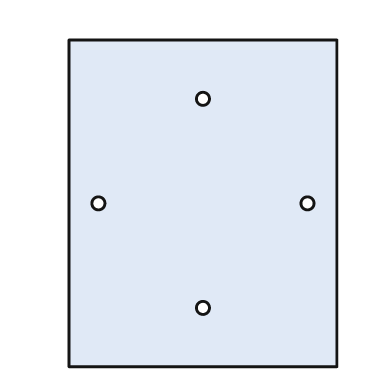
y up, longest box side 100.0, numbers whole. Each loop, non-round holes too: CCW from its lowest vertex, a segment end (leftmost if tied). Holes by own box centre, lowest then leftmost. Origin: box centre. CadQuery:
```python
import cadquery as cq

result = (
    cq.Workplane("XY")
    .moveTo(-41.0, -50.0)
    .lineTo(41.0, -50.0)
    .lineTo(41.0, 50.0)
    .lineTo(-41.0, 50.0)
    .close()
    .moveTo(0.0, -32.0)
    .circle(2.0)
    .moveTo(-32.0, 0.0)
    .circle(2.0)
    .moveTo(32.0, 0.0)
    .circle(2.0)
    .moveTo(0.0, 32.0)
    .circle(2.0)
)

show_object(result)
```